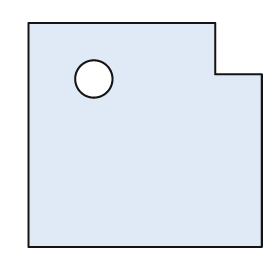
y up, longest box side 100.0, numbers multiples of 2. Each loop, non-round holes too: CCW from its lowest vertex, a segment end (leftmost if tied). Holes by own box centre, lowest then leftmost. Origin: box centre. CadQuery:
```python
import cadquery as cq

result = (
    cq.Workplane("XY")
    .moveTo(-50.0, -48.0)
    .lineTo(50.0, -48.0)
    .lineTo(50.0, 26.0)
    .lineTo(30.0, 26.0)
    .lineTo(30.0, 48.0)
    .lineTo(-50.0, 48.0)
    .close()
    .moveTo(-22.0, 24.0)
    .circle(8.0)
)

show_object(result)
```